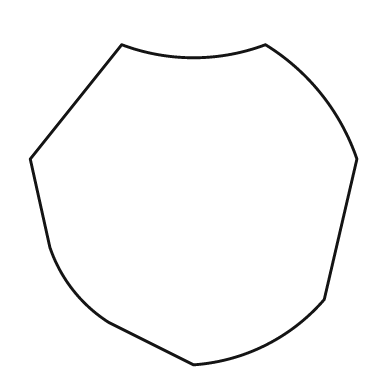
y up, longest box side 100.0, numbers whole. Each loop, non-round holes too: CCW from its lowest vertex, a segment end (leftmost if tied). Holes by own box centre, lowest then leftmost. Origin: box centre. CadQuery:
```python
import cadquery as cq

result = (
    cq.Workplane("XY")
    .moveTo(0.0, -49.0)
    .threePointArc((22.0, -43.0), (40.0, -29.0))
    .lineTo(50.0, 14.0)
    .threePointArc((39.0, 34.0), (22.0, 49.0))
    .threePointArc((0.0, 45.0), (-22.0, 49.0))
    .lineTo(-50.0, 14.0)
    .lineTo(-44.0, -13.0)
    .threePointArc((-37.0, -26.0), (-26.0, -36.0))
    .close()
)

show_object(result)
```